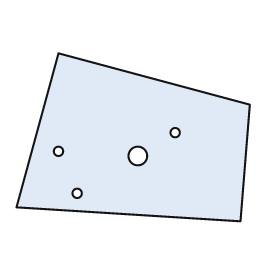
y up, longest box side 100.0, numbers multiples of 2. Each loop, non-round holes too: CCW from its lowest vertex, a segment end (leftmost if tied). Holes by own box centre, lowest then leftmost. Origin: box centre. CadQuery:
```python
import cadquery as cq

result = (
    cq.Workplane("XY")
    .moveTo(46.0, -36.0)
    .lineTo(50.0, 14.0)
    .lineTo(-32.0, 36.0)
    .lineTo(-50.0, -30.0)
    .close()
    .moveTo(-24.0, -24.0)
    .circle(2.0)
    .moveTo(2.0, -8.0)
    .circle(4.0)
    .moveTo(-32.0, -6.0)
    .circle(2.0)
    .moveTo(18.0, 2.0)
    .circle(2.0)
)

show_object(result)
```